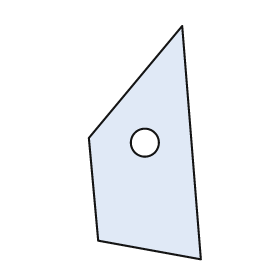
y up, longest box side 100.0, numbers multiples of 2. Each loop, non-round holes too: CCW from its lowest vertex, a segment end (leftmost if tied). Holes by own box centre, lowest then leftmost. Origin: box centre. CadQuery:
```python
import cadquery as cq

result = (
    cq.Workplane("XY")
    .moveTo(24.0, -50.0)
    .lineTo(16.0, 50.0)
    .lineTo(-24.0, 2.0)
    .lineTo(-20.0, -42.0)
    .close()
    .moveTo(0.0, 0.0)
    .circle(6.0)
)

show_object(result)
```